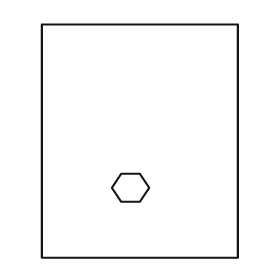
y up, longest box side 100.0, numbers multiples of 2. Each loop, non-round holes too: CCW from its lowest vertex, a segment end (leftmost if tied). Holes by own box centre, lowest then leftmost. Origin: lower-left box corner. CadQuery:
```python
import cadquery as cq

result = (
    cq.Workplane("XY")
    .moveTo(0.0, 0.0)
    .lineTo(84.0, 0.0)
    .lineTo(84.0, 100.0)
    .lineTo(0.0, 100.0)
    .close()
    .moveTo(34.0, 24.0)
    .lineTo(42.0, 24.0)
    .lineTo(46.0, 30.0)
    .lineTo(42.0, 36.0)
    .lineTo(34.0, 36.0)
    .lineTo(30.0, 30.0)
    .close()
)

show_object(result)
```